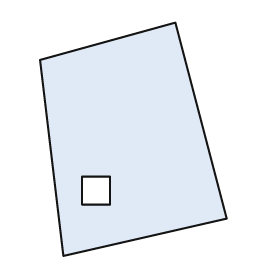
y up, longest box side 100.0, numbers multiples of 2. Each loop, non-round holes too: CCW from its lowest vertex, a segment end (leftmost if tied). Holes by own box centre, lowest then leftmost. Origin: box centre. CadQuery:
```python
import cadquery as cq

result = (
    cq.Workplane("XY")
    .moveTo(-30.0, -50.0)
    .lineTo(40.0, -34.0)
    .lineTo(18.0, 50.0)
    .lineTo(-40.0, 34.0)
    .close()
    .moveTo(-22.0, -28.0)
    .lineTo(-10.0, -28.0)
    .lineTo(-10.0, -16.0)
    .lineTo(-22.0, -16.0)
    .close()
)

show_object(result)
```